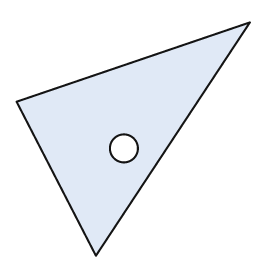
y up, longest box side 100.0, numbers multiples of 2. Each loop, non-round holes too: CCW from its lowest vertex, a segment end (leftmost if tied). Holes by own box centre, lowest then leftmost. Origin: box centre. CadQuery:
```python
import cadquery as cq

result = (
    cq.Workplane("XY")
    .moveTo(-16.0, -50.0)
    .lineTo(50.0, 50.0)
    .lineTo(-50.0, 16.0)
    .close()
    .moveTo(-4.0, -4.0)
    .circle(6.0)
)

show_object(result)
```